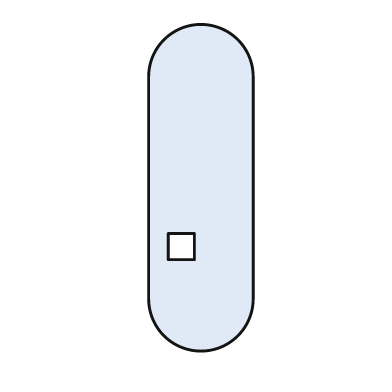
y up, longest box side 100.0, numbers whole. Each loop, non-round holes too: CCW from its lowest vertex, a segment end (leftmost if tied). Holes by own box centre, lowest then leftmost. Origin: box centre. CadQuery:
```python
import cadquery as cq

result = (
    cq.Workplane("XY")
    .moveTo(-16.0, -34.0)
    .threePointArc((0.0, -50.0), (16.0, -34.0))
    .lineTo(16.0, 34.0)
    .threePointArc((0.0, 50.0), (-16.0, 34.0))
    .close()
    .moveTo(-10.0, -22.0)
    .lineTo(-2.0, -22.0)
    .lineTo(-2.0, -14.0)
    .lineTo(-10.0, -14.0)
    .close()
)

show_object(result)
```